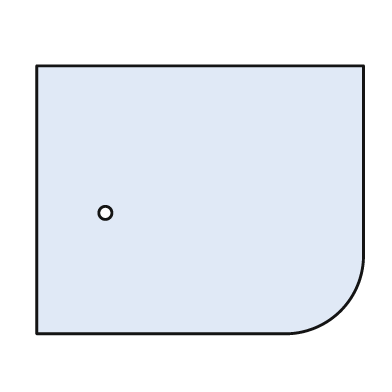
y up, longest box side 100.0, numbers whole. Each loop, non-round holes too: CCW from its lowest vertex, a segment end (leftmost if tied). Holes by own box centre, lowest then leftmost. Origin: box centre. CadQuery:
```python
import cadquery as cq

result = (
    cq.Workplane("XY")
    .moveTo(-50.0, -41.0)
    .lineTo(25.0, -41.0)
    .threePointArc((43.0, -34.0), (50.0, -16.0))
    .lineTo(50.0, 41.0)
    .lineTo(-50.0, 41.0)
    .close()
    .moveTo(-29.0, -4.0)
    .circle(2.0)
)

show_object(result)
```